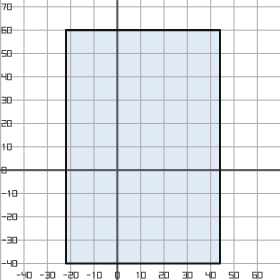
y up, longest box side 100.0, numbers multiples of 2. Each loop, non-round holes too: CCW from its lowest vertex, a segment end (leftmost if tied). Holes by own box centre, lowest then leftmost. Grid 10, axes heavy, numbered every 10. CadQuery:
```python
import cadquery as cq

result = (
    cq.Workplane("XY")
    .moveTo(-22.0, -40.0)
    .lineTo(44.0, -40.0)
    .lineTo(44.0, 60.0)
    .lineTo(-22.0, 60.0)
    .close()
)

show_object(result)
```